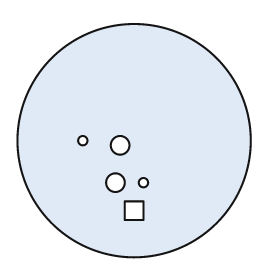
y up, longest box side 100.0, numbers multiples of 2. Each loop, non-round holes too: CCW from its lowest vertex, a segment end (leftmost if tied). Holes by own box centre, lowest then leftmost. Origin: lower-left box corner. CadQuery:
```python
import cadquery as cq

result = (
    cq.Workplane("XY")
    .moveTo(50.0, 50.0)
    .circle(50.0)
    .moveTo(46.0, 16.0)
    .lineTo(54.0, 16.0)
    .lineTo(54.0, 24.0)
    .lineTo(46.0, 24.0)
    .close()
    .moveTo(42.0, 32.0)
    .circle(4.0)
    .moveTo(54.0, 32.0)
    .circle(2.0)
    .moveTo(44.0, 48.0)
    .circle(4.0)
    .moveTo(28.0, 50.0)
    .circle(2.0)
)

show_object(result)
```